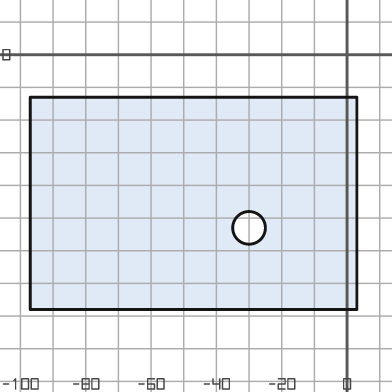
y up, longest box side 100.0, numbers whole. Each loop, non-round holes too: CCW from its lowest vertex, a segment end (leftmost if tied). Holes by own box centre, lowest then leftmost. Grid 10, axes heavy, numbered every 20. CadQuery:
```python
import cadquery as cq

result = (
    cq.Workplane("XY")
    .moveTo(-97.0, -78.0)
    .lineTo(3.0, -78.0)
    .lineTo(3.0, -13.0)
    .lineTo(-97.0, -13.0)
    .close()
    .moveTo(-30.0, -53.0)
    .circle(5.0)
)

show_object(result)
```